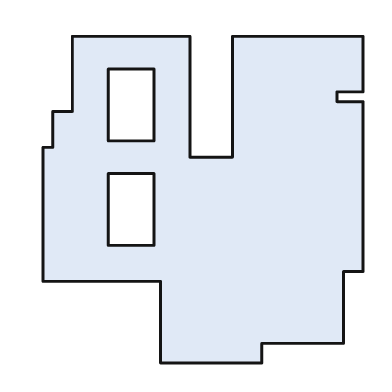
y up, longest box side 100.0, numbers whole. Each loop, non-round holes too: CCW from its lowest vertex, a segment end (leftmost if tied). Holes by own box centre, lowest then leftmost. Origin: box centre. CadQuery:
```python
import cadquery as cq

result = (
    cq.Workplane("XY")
    .moveTo(-13.0, -50.0)
    .lineTo(18.0, -50.0)
    .lineTo(18.0, -44.0)
    .lineTo(43.0, -44.0)
    .lineTo(43.0, -22.0)
    .lineTo(49.0, -22.0)
    .lineTo(49.0, 30.0)
    .lineTo(41.0, 30.0)
    .lineTo(41.0, 33.0)
    .lineTo(49.0, 33.0)
    .lineTo(49.0, 50.0)
    .lineTo(9.0, 50.0)
    .lineTo(9.0, 13.0)
    .lineTo(-4.0, 13.0)
    .lineTo(-4.0, 50.0)
    .lineTo(-40.0, 50.0)
    .lineTo(-40.0, 27.0)
    .lineTo(-46.0, 27.0)
    .lineTo(-46.0, 16.0)
    .lineTo(-49.0, 16.0)
    .lineTo(-49.0, -25.0)
    .lineTo(-13.0, -25.0)
    .close()
    .moveTo(-29.0, -14.0)
    .lineTo(-15.0, -14.0)
    .lineTo(-15.0, 8.0)
    .lineTo(-29.0, 8.0)
    .close()
    .moveTo(-29.0, 18.0)
    .lineTo(-15.0, 18.0)
    .lineTo(-15.0, 40.0)
    .lineTo(-29.0, 40.0)
    .close()
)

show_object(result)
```